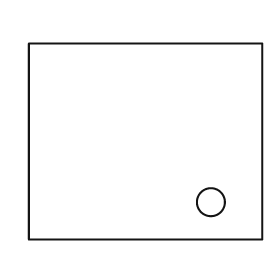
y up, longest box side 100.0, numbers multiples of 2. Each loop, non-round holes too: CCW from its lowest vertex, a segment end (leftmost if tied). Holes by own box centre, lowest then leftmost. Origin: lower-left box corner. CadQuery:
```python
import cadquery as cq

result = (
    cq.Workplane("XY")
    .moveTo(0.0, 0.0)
    .lineTo(100.0, 0.0)
    .lineTo(100.0, 84.0)
    .lineTo(0.0, 84.0)
    .close()
    .moveTo(78.0, 16.0)
    .circle(6.0)
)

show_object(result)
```